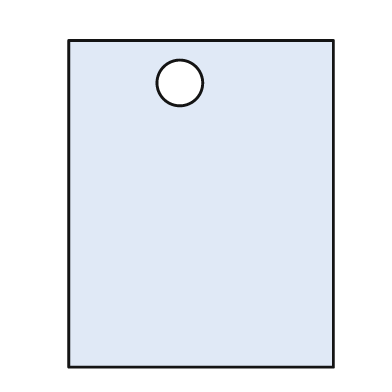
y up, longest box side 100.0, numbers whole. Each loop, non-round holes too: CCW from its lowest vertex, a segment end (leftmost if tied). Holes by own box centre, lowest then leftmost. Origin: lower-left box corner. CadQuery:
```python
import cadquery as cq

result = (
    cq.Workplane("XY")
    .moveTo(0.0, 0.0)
    .lineTo(81.0, 0.0)
    .lineTo(81.0, 100.0)
    .lineTo(0.0, 100.0)
    .close()
    .moveTo(34.0, 87.0)
    .circle(7.0)
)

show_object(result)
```